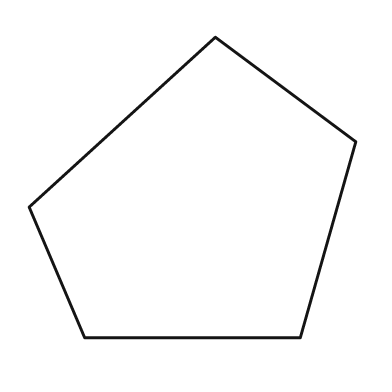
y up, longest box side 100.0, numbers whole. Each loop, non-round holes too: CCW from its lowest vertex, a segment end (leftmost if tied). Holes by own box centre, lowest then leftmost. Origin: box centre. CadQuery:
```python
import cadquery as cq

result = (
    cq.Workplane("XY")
    .moveTo(-33.0, -46.0)
    .lineTo(33.0, -46.0)
    .lineTo(50.0, 14.0)
    .lineTo(7.0, 46.0)
    .lineTo(-50.0, -6.0)
    .close()
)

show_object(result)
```